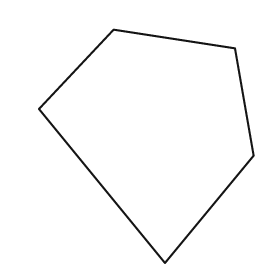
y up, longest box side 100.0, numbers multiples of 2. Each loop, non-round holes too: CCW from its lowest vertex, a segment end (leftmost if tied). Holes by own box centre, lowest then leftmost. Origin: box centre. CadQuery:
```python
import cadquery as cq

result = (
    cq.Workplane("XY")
    .moveTo(8.0, -50.0)
    .lineTo(46.0, -4.0)
    .lineTo(38.0, 42.0)
    .lineTo(-14.0, 50.0)
    .lineTo(-46.0, 16.0)
    .close()
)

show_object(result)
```